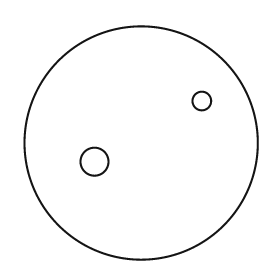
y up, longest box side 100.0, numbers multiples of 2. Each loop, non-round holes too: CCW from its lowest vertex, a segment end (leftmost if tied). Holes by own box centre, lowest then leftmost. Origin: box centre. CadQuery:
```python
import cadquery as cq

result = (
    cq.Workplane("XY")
    .moveTo(0.0, 0.0)
    .circle(50.0)
    .moveTo(-20.0, -8.0)
    .circle(6.0)
    .moveTo(26.0, 18.0)
    .circle(4.0)
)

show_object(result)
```